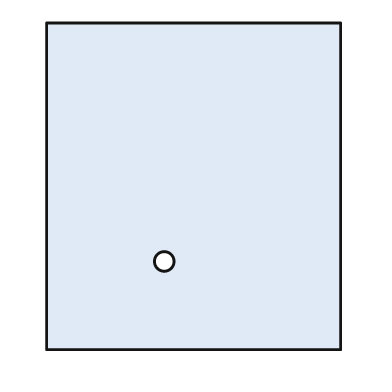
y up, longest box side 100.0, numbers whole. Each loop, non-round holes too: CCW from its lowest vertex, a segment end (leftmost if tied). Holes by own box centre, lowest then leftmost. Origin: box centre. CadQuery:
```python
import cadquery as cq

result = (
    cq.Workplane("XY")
    .moveTo(-45.0, -50.0)
    .lineTo(45.0, -50.0)
    .lineTo(45.0, 50.0)
    .lineTo(-45.0, 50.0)
    .close()
    .moveTo(-9.0, -23.0)
    .circle(3.0)
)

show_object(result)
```